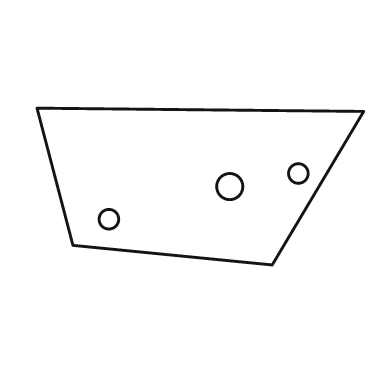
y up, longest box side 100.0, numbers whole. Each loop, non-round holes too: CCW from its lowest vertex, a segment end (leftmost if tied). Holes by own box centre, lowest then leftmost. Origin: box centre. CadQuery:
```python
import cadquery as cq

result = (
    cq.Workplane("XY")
    .moveTo(22.0, -24.0)
    .lineTo(50.0, 23.0)
    .lineTo(-50.0, 24.0)
    .lineTo(-39.0, -18.0)
    .close()
    .moveTo(-28.0, -10.0)
    .circle(3.0)
    .moveTo(9.0, 0.0)
    .circle(4.0)
    .moveTo(30.0, 4.0)
    .circle(3.0)
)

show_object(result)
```